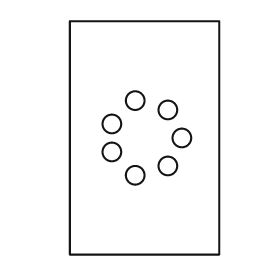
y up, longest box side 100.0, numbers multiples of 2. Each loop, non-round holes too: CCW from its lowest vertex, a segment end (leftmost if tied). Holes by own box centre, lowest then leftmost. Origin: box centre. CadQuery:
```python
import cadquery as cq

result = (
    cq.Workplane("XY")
    .moveTo(-32.0, -50.0)
    .lineTo(32.0, -50.0)
    .lineTo(32.0, 50.0)
    .lineTo(-32.0, 50.0)
    .close()
    .moveTo(-4.0, -16.0)
    .circle(4.0)
    .moveTo(10.0, -12.0)
    .circle(4.0)
    .moveTo(-14.0, -6.0)
    .circle(4.0)
    .moveTo(16.0, 0.0)
    .circle(4.0)
    .moveTo(-14.0, 6.0)
    .circle(4.0)
    .moveTo(10.0, 12.0)
    .circle(4.0)
    .moveTo(-4.0, 16.0)
    .circle(4.0)
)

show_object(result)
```